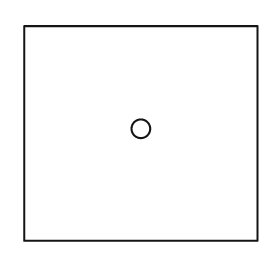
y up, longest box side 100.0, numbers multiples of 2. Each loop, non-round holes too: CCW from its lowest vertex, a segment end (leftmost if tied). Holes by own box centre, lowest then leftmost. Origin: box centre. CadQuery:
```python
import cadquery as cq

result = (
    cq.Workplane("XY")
    .moveTo(-50.0, -46.0)
    .lineTo(50.0, -46.0)
    .lineTo(50.0, 46.0)
    .lineTo(-50.0, 46.0)
    .close()
    .moveTo(0.0, 2.0)
    .circle(4.0)
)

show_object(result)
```